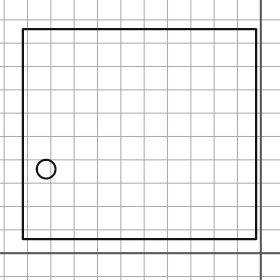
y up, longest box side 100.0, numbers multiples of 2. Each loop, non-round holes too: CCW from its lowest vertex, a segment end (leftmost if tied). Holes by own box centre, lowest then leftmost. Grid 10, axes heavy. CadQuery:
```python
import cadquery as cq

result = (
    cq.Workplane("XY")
    .moveTo(-102.0, 6.0)
    .lineTo(-2.0, 6.0)
    .lineTo(-2.0, 96.0)
    .lineTo(-102.0, 96.0)
    .close()
    .moveTo(-92.0, 36.0)
    .circle(4.0)
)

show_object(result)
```